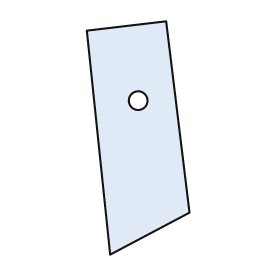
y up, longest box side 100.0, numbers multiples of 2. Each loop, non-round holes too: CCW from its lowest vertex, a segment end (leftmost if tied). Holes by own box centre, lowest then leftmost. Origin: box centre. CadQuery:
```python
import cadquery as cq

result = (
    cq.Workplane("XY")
    .moveTo(-12.0, -50.0)
    .lineTo(22.0, -32.0)
    .lineTo(12.0, 50.0)
    .lineTo(-22.0, 46.0)
    .close()
    .moveTo(0.0, 16.0)
    .circle(4.0)
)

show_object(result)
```